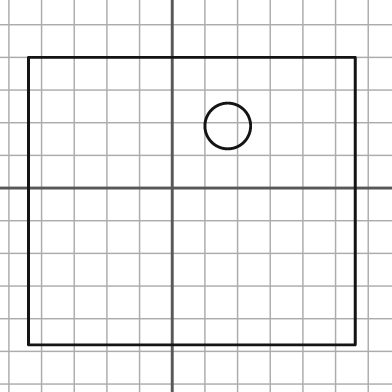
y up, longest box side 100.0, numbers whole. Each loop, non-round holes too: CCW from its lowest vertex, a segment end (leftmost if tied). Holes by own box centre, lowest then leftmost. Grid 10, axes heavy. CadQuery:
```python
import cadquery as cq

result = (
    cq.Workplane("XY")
    .moveTo(-44.0, -48.0)
    .lineTo(56.0, -48.0)
    .lineTo(56.0, 40.0)
    .lineTo(-44.0, 40.0)
    .close()
    .moveTo(17.0, 19.0)
    .circle(7.0)
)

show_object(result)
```